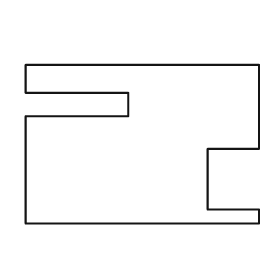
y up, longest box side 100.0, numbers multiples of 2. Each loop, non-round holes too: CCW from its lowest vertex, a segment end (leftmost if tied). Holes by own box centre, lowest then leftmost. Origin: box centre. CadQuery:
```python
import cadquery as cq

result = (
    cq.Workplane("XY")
    .moveTo(-50.0, -34.0)
    .lineTo(50.0, -34.0)
    .lineTo(50.0, -28.0)
    .lineTo(28.0, -28.0)
    .lineTo(28.0, -2.0)
    .lineTo(50.0, -2.0)
    .lineTo(50.0, 34.0)
    .lineTo(-50.0, 34.0)
    .lineTo(-50.0, 22.0)
    .lineTo(-6.0, 22.0)
    .lineTo(-6.0, 12.0)
    .lineTo(-50.0, 12.0)
    .close()
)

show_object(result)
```